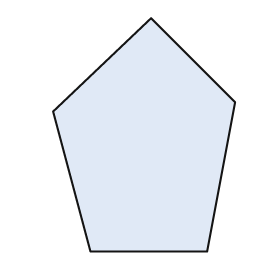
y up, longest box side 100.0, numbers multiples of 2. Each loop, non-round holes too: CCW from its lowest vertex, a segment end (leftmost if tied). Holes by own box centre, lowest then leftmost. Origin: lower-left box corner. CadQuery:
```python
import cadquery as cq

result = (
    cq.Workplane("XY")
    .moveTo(16.0, 0.0)
    .lineTo(66.0, 0.0)
    .lineTo(78.0, 64.0)
    .lineTo(42.0, 100.0)
    .lineTo(0.0, 60.0)
    .close()
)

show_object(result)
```